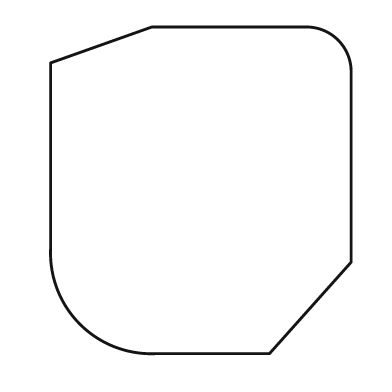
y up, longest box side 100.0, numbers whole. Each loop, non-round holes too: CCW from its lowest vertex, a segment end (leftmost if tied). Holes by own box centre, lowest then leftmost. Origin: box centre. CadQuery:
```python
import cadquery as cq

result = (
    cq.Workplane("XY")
    .moveTo(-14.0, -50.0)
    .lineTo(21.0, -50.0)
    .lineTo(46.0, -22.0)
    .lineTo(46.0, 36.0)
    .threePointArc((42.0, 46.0), (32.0, 50.0))
    .lineTo(-15.0, 50.0)
    .lineTo(-46.0, 39.0)
    .lineTo(-46.0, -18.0)
    .threePointArc((-37.0, -41.0), (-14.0, -50.0))
    .close()
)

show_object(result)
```